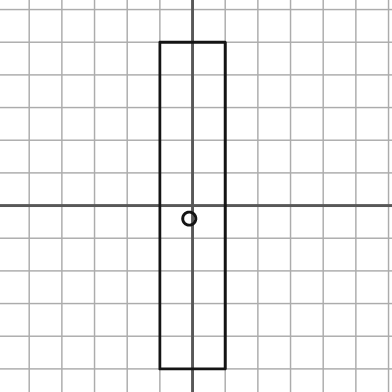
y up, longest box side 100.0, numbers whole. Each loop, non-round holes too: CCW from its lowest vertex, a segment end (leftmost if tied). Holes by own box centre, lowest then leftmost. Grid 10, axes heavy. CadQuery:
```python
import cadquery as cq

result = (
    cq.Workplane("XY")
    .moveTo(-10.0, -50.0)
    .lineTo(10.0, -50.0)
    .lineTo(10.0, 50.0)
    .lineTo(-10.0, 50.0)
    .close()
    .moveTo(-1.0, -4.0)
    .circle(2.0)
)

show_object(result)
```